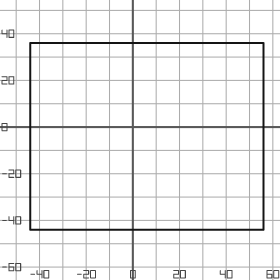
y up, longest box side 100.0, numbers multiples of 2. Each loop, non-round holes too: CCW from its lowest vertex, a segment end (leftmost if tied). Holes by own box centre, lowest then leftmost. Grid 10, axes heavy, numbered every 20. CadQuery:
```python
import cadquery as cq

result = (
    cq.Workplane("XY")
    .moveTo(-44.0, -44.0)
    .lineTo(56.0, -44.0)
    .lineTo(56.0, 36.0)
    .lineTo(-44.0, 36.0)
    .close()
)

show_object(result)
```